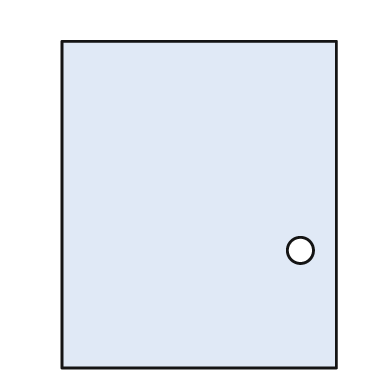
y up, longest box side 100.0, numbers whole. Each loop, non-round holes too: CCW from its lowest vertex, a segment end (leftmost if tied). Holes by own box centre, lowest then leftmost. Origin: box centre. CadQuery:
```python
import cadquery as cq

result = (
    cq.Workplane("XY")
    .moveTo(-42.0, -50.0)
    .lineTo(42.0, -50.0)
    .lineTo(42.0, 50.0)
    .lineTo(-42.0, 50.0)
    .close()
    .moveTo(31.0, -14.0)
    .circle(4.0)
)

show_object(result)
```